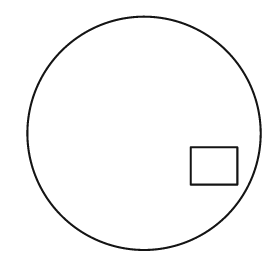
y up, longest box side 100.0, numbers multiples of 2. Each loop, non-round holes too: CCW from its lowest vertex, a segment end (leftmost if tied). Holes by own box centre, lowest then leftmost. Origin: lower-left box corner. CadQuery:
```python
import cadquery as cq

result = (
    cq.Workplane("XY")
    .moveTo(50.0, 50.0)
    .circle(50.0)
    .moveTo(70.0, 28.0)
    .lineTo(90.0, 28.0)
    .lineTo(90.0, 44.0)
    .lineTo(70.0, 44.0)
    .close()
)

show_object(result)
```